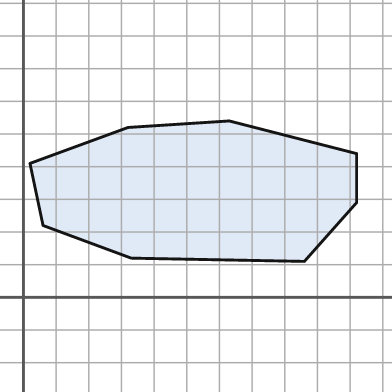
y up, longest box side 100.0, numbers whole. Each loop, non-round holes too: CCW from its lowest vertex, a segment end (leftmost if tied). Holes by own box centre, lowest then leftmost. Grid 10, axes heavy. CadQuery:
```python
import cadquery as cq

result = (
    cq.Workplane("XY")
    .moveTo(86.0, 11.0)
    .lineTo(102.0, 29.0)
    .lineTo(102.0, 44.0)
    .lineTo(63.0, 54.0)
    .lineTo(32.0, 52.0)
    .lineTo(2.0, 41.0)
    .lineTo(6.0, 22.0)
    .lineTo(33.0, 12.0)
    .close()
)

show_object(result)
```